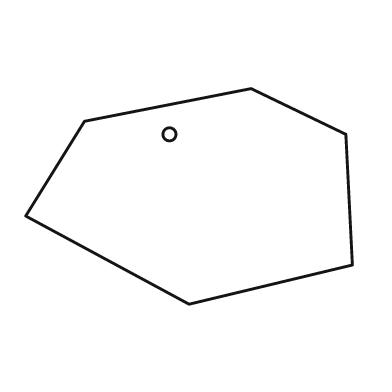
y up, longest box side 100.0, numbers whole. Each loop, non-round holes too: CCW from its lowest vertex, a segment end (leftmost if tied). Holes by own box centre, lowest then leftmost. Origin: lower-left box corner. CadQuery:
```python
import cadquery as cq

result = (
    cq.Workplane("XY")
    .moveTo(50.0, 0.0)
    .lineTo(100.0, 12.0)
    .lineTo(98.0, 52.0)
    .lineTo(69.0, 66.0)
    .lineTo(18.0, 56.0)
    .lineTo(0.0, 27.0)
    .close()
    .moveTo(44.0, 52.0)
    .circle(2.0)
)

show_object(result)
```